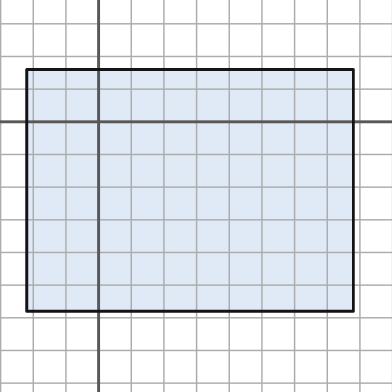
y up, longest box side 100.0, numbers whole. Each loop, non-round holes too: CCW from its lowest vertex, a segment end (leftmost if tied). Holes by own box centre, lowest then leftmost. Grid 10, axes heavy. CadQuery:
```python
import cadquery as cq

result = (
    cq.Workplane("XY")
    .moveTo(-22.0, -58.0)
    .lineTo(78.0, -58.0)
    .lineTo(78.0, 16.0)
    .lineTo(-22.0, 16.0)
    .close()
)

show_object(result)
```